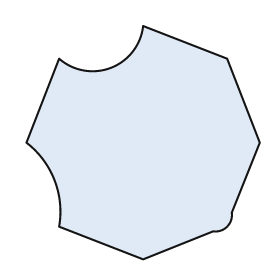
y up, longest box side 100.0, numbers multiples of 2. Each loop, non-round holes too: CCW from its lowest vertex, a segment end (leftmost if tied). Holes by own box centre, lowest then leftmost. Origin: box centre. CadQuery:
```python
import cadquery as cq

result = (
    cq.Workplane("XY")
    .moveTo(0.0, -50.0)
    .lineTo(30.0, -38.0)
    .threePointArc((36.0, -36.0), (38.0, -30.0))
    .lineTo(50.0, 0.0)
    .lineTo(36.0, 36.0)
    .lineTo(0.0, 50.0)
    .threePointArc((-14.0, 32.0), (-36.0, 36.0))
    .lineTo(-50.0, 0.0)
    .threePointArc((-38.0, -16.0), (-36.0, -36.0))
    .close()
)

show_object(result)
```